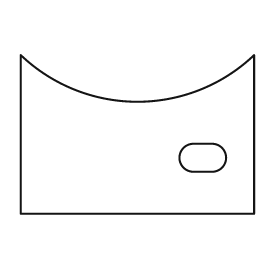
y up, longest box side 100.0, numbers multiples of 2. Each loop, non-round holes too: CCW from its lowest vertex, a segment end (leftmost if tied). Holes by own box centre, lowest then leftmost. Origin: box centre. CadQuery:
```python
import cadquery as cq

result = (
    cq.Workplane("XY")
    .moveTo(-50.0, -34.0)
    .lineTo(50.0, -34.0)
    .lineTo(50.0, 34.0)
    .threePointArc((0.0, 14.0), (-50.0, 34.0))
    .close()
    .moveTo(24.0, -16.0)
    .lineTo(32.0, -16.0)
    .threePointArc((38.0, -10.0), (32.0, -4.0))
    .lineTo(24.0, -4.0)
    .threePointArc((18.0, -10.0), (24.0, -16.0))
    .close()
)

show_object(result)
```